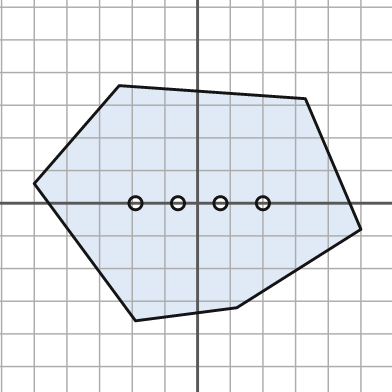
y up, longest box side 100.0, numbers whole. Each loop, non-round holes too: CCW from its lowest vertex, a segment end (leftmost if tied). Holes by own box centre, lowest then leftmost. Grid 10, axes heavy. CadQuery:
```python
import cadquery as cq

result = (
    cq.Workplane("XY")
    .moveTo(-19.0, -36.0)
    .lineTo(12.0, -32.0)
    .lineTo(50.0, -8.0)
    .lineTo(33.0, 32.0)
    .lineTo(-24.0, 36.0)
    .lineTo(-50.0, 6.0)
    .close()
    .moveTo(-19.0, 0.0)
    .circle(2.0)
    .moveTo(-6.0, 0.0)
    .circle(2.0)
    .moveTo(7.0, 0.0)
    .circle(2.0)
    .moveTo(20.0, 0.0)
    .circle(2.0)
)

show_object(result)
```